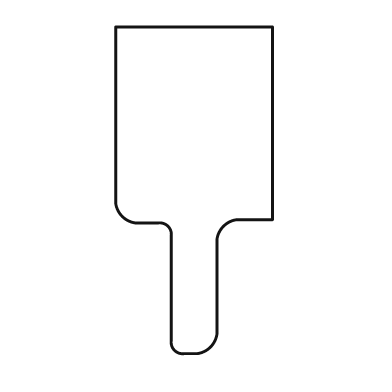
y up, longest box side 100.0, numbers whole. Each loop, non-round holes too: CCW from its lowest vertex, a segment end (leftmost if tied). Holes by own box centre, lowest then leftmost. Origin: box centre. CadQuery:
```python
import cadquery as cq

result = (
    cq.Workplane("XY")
    .moveTo(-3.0, -50.0)
    .lineTo(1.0, -50.0)
    .threePointArc((5.0, -48.0), (7.0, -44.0))
    .lineTo(7.0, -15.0)
    .threePointArc((9.0, -11.0), (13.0, -9.0))
    .lineTo(24.0, -9.0)
    .lineTo(24.0, 50.0)
    .lineTo(-24.0, 50.0)
    .lineTo(-24.0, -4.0)
    .threePointArc((-22.0, -8.0), (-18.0, -10.0))
    .lineTo(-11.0, -10.0)
    .threePointArc((-8.0, -11.0), (-7.0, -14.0))
    .lineTo(-7.0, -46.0)
    .threePointArc((-6.0, -49.0), (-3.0, -50.0))
    .close()
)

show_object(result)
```